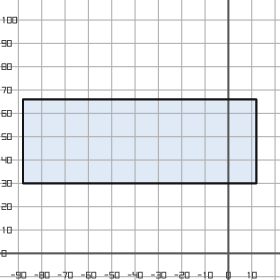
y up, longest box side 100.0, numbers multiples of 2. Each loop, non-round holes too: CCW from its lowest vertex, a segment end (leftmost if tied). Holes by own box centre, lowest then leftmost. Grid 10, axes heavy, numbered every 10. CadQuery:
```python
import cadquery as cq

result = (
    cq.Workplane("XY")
    .moveTo(-88.0, 30.0)
    .lineTo(12.0, 30.0)
    .lineTo(12.0, 66.0)
    .lineTo(-88.0, 66.0)
    .close()
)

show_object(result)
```